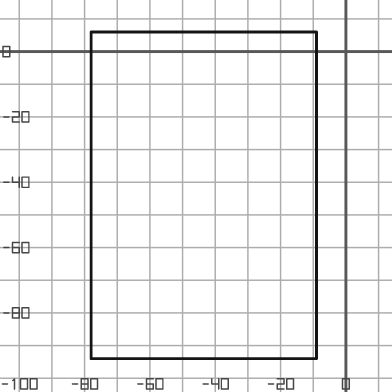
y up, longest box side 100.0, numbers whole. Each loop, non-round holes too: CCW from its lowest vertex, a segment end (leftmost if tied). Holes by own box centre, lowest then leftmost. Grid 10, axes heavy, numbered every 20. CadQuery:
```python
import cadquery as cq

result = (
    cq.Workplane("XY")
    .moveTo(-78.0, -94.0)
    .lineTo(-9.0, -94.0)
    .lineTo(-9.0, 6.0)
    .lineTo(-78.0, 6.0)
    .close()
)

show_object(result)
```